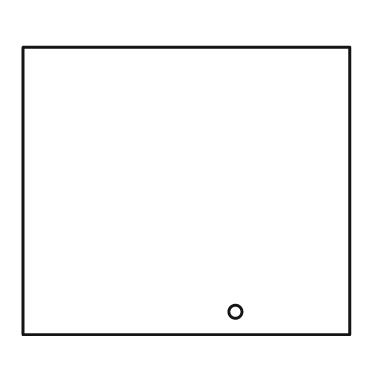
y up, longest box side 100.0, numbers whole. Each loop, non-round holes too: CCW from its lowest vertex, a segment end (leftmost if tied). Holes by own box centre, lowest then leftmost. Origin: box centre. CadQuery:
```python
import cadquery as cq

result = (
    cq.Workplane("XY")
    .moveTo(-50.0, -44.0)
    .lineTo(50.0, -44.0)
    .lineTo(50.0, 44.0)
    .lineTo(-50.0, 44.0)
    .close()
    .moveTo(15.0, -37.0)
    .circle(2.0)
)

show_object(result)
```